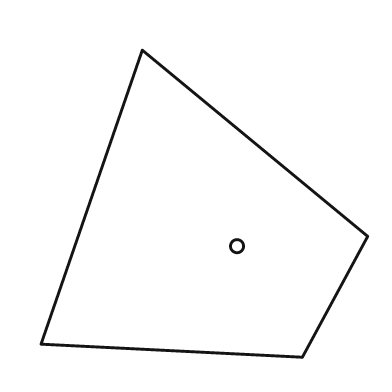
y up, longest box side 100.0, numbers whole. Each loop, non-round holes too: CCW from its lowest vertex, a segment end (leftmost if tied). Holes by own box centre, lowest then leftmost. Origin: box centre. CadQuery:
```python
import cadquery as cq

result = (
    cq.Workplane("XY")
    .moveTo(30.0, -47.0)
    .lineTo(50.0, -10.0)
    .lineTo(-19.0, 47.0)
    .lineTo(-50.0, -43.0)
    .close()
    .moveTo(10.0, -13.0)
    .circle(2.0)
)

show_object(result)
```